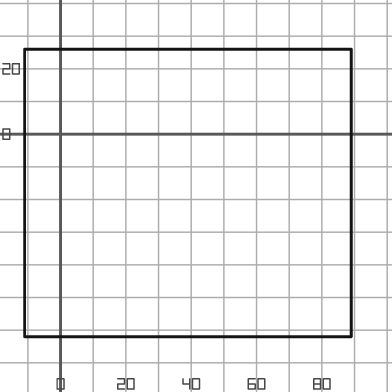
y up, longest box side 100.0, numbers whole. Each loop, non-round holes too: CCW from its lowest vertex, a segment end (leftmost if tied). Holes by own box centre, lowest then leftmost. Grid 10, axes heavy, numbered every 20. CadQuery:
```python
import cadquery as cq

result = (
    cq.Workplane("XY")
    .moveTo(-11.0, -62.0)
    .lineTo(89.0, -62.0)
    .lineTo(89.0, 26.0)
    .lineTo(-11.0, 26.0)
    .close()
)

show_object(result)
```